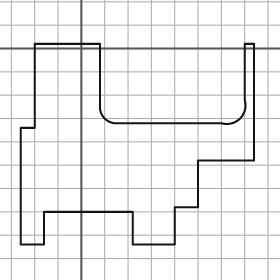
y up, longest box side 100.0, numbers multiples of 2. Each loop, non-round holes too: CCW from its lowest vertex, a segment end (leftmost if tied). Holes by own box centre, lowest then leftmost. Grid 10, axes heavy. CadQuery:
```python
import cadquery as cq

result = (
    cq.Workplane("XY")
    .moveTo(-26.0, -84.0)
    .lineTo(-16.0, -84.0)
    .lineTo(-16.0, -70.0)
    .lineTo(22.0, -70.0)
    .lineTo(22.0, -84.0)
    .lineTo(40.0, -84.0)
    .lineTo(40.0, -68.0)
    .lineTo(50.0, -68.0)
    .lineTo(50.0, -48.0)
    .lineTo(74.0, -48.0)
    .lineTo(74.0, 2.0)
    .lineTo(70.0, 2.0)
    .lineTo(70.0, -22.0)
    .threePointArc((68.0, -30.0), (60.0, -32.0))
    .lineTo(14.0, -32.0)
    .threePointArc((10.0, -30.0), (8.0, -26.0))
    .lineTo(8.0, 2.0)
    .lineTo(-20.0, 2.0)
    .lineTo(-20.0, -34.0)
    .lineTo(-26.0, -34.0)
    .close()
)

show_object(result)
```